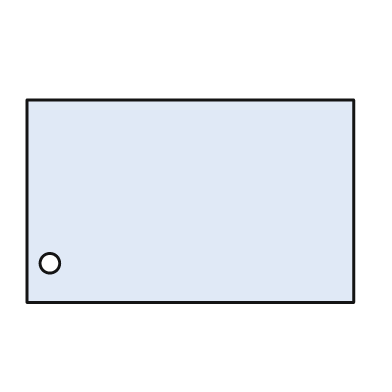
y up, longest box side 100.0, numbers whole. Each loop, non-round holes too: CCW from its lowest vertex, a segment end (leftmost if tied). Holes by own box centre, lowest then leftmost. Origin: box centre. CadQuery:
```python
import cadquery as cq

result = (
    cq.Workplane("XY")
    .moveTo(-50.0, -31.0)
    .lineTo(50.0, -31.0)
    .lineTo(50.0, 31.0)
    .lineTo(-50.0, 31.0)
    .close()
    .moveTo(-43.0, -19.0)
    .circle(3.0)
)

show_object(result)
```